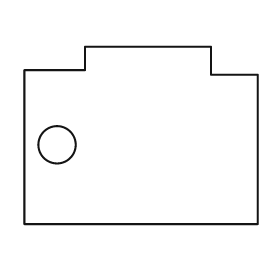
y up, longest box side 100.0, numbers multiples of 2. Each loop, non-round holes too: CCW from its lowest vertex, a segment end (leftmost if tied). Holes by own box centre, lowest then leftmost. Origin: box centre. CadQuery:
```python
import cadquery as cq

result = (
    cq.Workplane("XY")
    .moveTo(-50.0, -38.0)
    .lineTo(50.0, -38.0)
    .lineTo(50.0, 26.0)
    .lineTo(30.0, 26.0)
    .lineTo(30.0, 38.0)
    .lineTo(-24.0, 38.0)
    .lineTo(-24.0, 28.0)
    .lineTo(-50.0, 28.0)
    .close()
    .moveTo(-36.0, -4.0)
    .circle(8.0)
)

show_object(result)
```